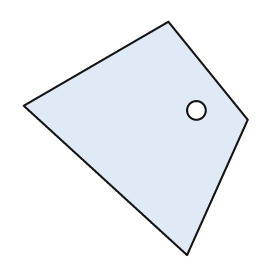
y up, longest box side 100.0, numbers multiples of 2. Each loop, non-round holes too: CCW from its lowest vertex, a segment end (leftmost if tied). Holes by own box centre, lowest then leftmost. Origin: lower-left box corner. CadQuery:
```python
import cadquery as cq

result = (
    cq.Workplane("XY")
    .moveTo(70.0, 0.0)
    .lineTo(96.0, 58.0)
    .lineTo(62.0, 100.0)
    .lineTo(0.0, 64.0)
    .close()
    .moveTo(74.0, 62.0)
    .circle(4.0)
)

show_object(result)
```